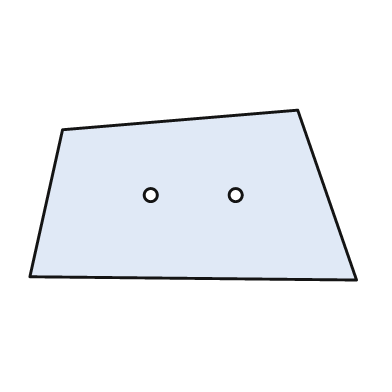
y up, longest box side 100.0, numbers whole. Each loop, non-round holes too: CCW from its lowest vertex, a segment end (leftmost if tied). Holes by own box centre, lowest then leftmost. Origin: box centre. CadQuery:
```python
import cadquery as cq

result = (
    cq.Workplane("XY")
    .moveTo(50.0, -26.0)
    .lineTo(32.0, 26.0)
    .lineTo(-40.0, 20.0)
    .lineTo(-50.0, -25.0)
    .close()
    .moveTo(-13.0, 0.0)
    .circle(2.0)
    .moveTo(13.0, 0.0)
    .circle(2.0)
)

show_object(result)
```